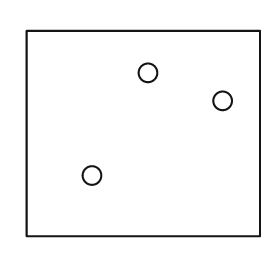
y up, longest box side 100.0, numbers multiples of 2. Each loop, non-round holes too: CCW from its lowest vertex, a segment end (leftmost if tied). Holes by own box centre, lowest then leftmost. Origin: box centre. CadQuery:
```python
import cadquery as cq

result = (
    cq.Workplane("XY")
    .moveTo(-50.0, -44.0)
    .lineTo(50.0, -44.0)
    .lineTo(50.0, 44.0)
    .lineTo(-50.0, 44.0)
    .close()
    .moveTo(-22.0, -18.0)
    .circle(4.0)
    .moveTo(34.0, 14.0)
    .circle(4.0)
    .moveTo(2.0, 26.0)
    .circle(4.0)
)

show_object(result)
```